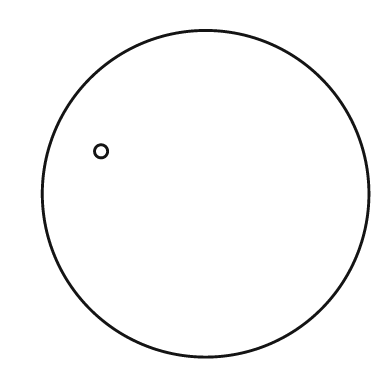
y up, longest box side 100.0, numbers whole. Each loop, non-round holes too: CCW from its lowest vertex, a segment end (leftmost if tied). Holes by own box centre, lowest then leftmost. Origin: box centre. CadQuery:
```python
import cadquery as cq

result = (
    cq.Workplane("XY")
    .moveTo(0.0, 0.0)
    .circle(50.0)
    .moveTo(-32.0, 13.0)
    .circle(2.0)
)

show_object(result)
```